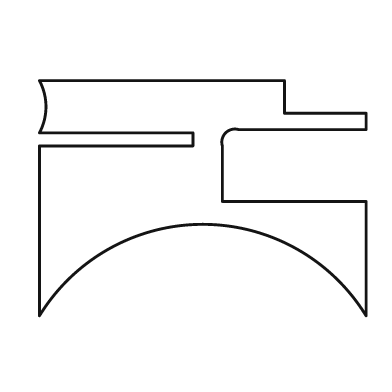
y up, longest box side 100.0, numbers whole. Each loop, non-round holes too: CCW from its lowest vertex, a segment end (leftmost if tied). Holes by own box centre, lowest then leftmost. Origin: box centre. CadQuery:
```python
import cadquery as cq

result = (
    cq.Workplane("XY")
    .moveTo(-50.0, -36.0)
    .threePointArc((0.0, -8.0), (50.0, -36.0))
    .lineTo(50.0, -1.0)
    .lineTo(6.0, -1.0)
    .lineTo(6.0, 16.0)
    .threePointArc((7.0, 20.0), (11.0, 21.0))
    .lineTo(50.0, 21.0)
    .lineTo(50.0, 26.0)
    .lineTo(25.0, 26.0)
    .lineTo(25.0, 36.0)
    .lineTo(-50.0, 36.0)
    .threePointArc((-48.0, 28.0), (-50.0, 20.0))
    .lineTo(-3.0, 20.0)
    .lineTo(-3.0, 16.0)
    .lineTo(-50.0, 16.0)
    .close()
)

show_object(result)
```